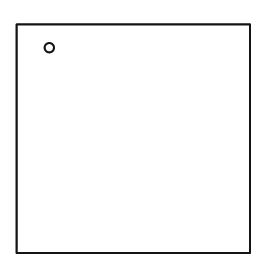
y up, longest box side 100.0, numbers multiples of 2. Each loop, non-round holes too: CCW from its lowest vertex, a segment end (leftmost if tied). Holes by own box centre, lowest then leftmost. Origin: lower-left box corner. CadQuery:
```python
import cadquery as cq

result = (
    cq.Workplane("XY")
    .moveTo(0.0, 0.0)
    .lineTo(100.0, 0.0)
    .lineTo(100.0, 98.0)
    .lineTo(0.0, 98.0)
    .close()
    .moveTo(14.0, 88.0)
    .circle(2.0)
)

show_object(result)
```